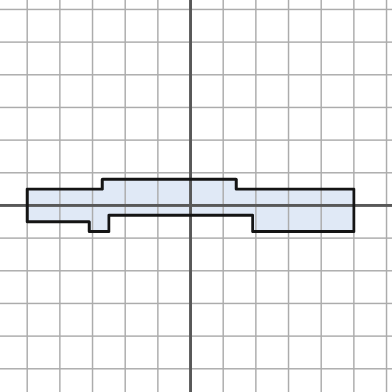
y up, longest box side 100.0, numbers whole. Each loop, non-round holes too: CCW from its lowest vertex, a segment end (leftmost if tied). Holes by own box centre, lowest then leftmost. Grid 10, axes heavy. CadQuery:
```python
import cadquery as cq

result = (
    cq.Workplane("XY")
    .moveTo(-31.0, -8.0)
    .lineTo(-25.0, -8.0)
    .lineTo(-25.0, -3.0)
    .lineTo(19.0, -3.0)
    .lineTo(19.0, -8.0)
    .lineTo(50.0, -8.0)
    .lineTo(50.0, 5.0)
    .lineTo(14.0, 5.0)
    .lineTo(14.0, 8.0)
    .lineTo(-27.0, 8.0)
    .lineTo(-27.0, 5.0)
    .lineTo(-50.0, 5.0)
    .lineTo(-50.0, -5.0)
    .lineTo(-31.0, -5.0)
    .close()
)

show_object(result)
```